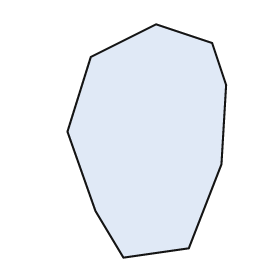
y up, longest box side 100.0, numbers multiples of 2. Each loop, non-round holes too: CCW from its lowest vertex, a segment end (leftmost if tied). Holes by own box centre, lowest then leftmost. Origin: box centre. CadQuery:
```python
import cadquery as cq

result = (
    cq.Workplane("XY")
    .moveTo(-10.0, -50.0)
    .lineTo(18.0, -46.0)
    .lineTo(32.0, -10.0)
    .lineTo(34.0, 24.0)
    .lineTo(28.0, 42.0)
    .lineTo(4.0, 50.0)
    .lineTo(-24.0, 36.0)
    .lineTo(-34.0, 4.0)
    .lineTo(-22.0, -30.0)
    .close()
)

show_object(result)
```